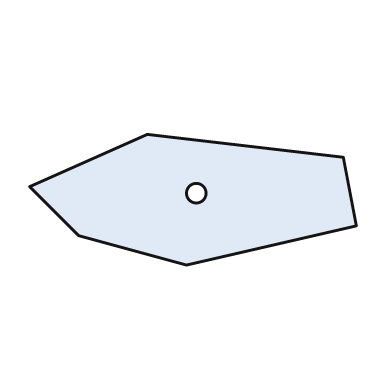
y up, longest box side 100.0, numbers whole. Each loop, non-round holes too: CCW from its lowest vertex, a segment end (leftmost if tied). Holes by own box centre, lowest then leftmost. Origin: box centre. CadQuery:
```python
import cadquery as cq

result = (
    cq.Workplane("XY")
    .moveTo(-2.0, -20.0)
    .lineTo(50.0, -8.0)
    .lineTo(46.0, 13.0)
    .lineTo(-14.0, 20.0)
    .lineTo(-50.0, 4.0)
    .lineTo(-35.0, -11.0)
    .close()
    .moveTo(1.0, 2.0)
    .circle(3.0)
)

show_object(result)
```